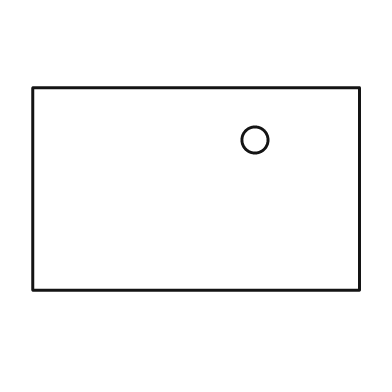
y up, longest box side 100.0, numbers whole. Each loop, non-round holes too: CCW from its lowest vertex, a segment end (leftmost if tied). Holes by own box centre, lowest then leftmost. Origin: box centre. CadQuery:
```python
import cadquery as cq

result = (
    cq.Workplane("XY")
    .moveTo(-50.0, -31.0)
    .lineTo(50.0, -31.0)
    .lineTo(50.0, 31.0)
    .lineTo(-50.0, 31.0)
    .close()
    .moveTo(18.0, 15.0)
    .circle(4.0)
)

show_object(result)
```